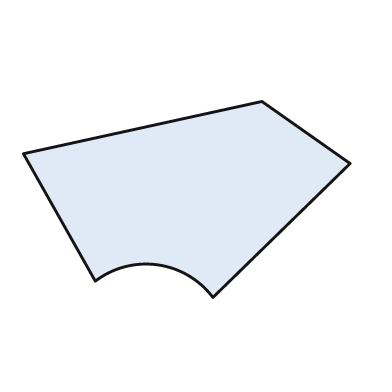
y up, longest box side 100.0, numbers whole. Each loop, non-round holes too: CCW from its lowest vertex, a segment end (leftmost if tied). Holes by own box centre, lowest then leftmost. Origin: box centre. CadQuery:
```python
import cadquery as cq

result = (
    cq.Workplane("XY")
    .moveTo(8.0, -30.0)
    .lineTo(50.0, 11.0)
    .lineTo(23.0, 30.0)
    .lineTo(-50.0, 14.0)
    .lineTo(-28.0, -25.0)
    .threePointArc((-9.0, -20.0), (8.0, -30.0))
    .close()
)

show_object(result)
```